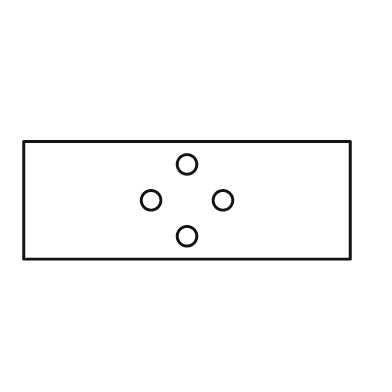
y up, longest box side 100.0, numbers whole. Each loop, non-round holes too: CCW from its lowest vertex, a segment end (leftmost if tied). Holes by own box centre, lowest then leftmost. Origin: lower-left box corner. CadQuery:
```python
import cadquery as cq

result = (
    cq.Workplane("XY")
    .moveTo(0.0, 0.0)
    .lineTo(100.0, 0.0)
    .lineTo(100.0, 36.0)
    .lineTo(0.0, 36.0)
    .close()
    .moveTo(50.0, 7.0)
    .circle(3.0)
    .moveTo(39.0, 18.0)
    .circle(3.0)
    .moveTo(61.0, 18.0)
    .circle(3.0)
    .moveTo(50.0, 29.0)
    .circle(3.0)
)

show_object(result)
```